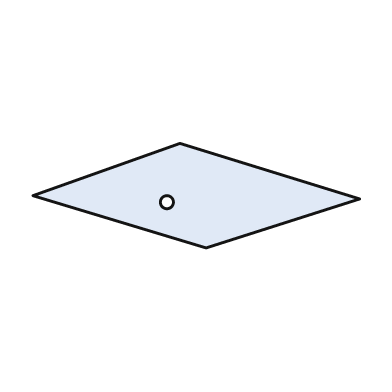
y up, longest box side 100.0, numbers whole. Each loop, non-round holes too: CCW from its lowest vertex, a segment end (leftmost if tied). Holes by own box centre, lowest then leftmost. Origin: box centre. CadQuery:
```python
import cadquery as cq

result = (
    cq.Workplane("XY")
    .moveTo(3.0, -16.0)
    .lineTo(50.0, -1.0)
    .lineTo(-5.0, 16.0)
    .lineTo(-50.0, 0.0)
    .close()
    .moveTo(-9.0, -2.0)
    .circle(2.0)
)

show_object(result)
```